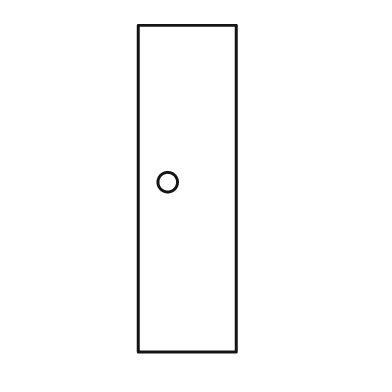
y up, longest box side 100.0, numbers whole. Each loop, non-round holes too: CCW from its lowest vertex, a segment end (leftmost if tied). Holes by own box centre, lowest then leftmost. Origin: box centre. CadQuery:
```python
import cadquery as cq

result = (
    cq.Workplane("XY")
    .moveTo(-15.0, -50.0)
    .lineTo(15.0, -50.0)
    .lineTo(15.0, 50.0)
    .lineTo(-15.0, 50.0)
    .close()
    .moveTo(-6.0, 2.0)
    .circle(3.0)
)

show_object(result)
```